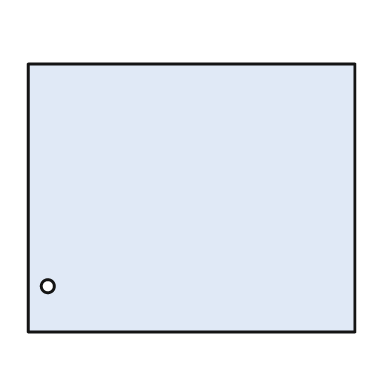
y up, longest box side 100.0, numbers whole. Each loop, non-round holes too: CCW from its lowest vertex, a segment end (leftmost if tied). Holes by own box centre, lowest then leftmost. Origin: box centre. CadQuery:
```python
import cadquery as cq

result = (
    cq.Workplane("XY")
    .moveTo(-50.0, -41.0)
    .lineTo(50.0, -41.0)
    .lineTo(50.0, 41.0)
    .lineTo(-50.0, 41.0)
    .close()
    .moveTo(-44.0, -27.0)
    .circle(2.0)
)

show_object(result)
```